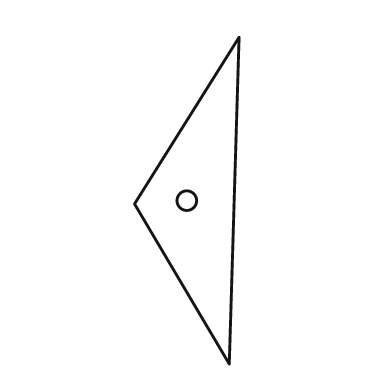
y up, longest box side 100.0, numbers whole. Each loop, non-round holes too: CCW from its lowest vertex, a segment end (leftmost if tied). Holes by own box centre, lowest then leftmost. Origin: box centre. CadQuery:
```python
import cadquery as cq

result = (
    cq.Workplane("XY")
    .moveTo(13.0, -50.0)
    .lineTo(16.0, 50.0)
    .lineTo(-16.0, -1.0)
    .close()
    .moveTo(0.0, 0.0)
    .circle(3.0)
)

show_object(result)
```